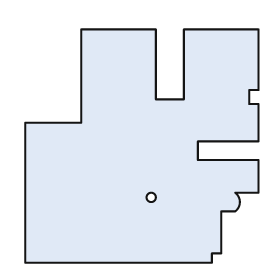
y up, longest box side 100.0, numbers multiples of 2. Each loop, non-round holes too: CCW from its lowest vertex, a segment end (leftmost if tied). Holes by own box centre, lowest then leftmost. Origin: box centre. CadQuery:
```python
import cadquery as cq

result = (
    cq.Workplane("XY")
    .moveTo(-50.0, -50.0)
    .lineTo(30.0, -50.0)
    .lineTo(30.0, -46.0)
    .lineTo(34.0, -46.0)
    .lineTo(34.0, -28.0)
    .lineTo(40.0, -28.0)
    .threePointArc((42.0, -24.0), (40.0, -20.0))
    .lineTo(50.0, -20.0)
    .lineTo(50.0, -6.0)
    .lineTo(24.0, -6.0)
    .lineTo(24.0, 2.0)
    .lineTo(50.0, 2.0)
    .lineTo(50.0, 18.0)
    .lineTo(46.0, 18.0)
    .lineTo(46.0, 24.0)
    .lineTo(50.0, 24.0)
    .lineTo(50.0, 50.0)
    .lineTo(18.0, 50.0)
    .lineTo(18.0, 20.0)
    .lineTo(6.0, 20.0)
    .lineTo(6.0, 50.0)
    .lineTo(-26.0, 50.0)
    .lineTo(-26.0, 10.0)
    .lineTo(-50.0, 10.0)
    .close()
    .moveTo(4.0, -22.0)
    .circle(2.0)
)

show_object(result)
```